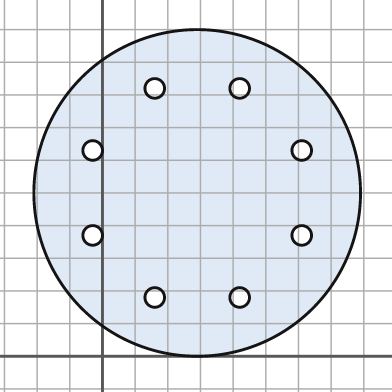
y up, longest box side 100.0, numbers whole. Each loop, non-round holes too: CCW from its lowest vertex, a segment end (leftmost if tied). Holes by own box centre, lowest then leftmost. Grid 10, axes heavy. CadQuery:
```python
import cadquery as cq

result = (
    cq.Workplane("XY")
    .moveTo(29.0, 50.0)
    .circle(50.0)
    .moveTo(16.0, 18.0)
    .circle(3.0)
    .moveTo(42.0, 18.0)
    .circle(3.0)
    .moveTo(-3.0, 37.0)
    .circle(3.0)
    .moveTo(61.0, 37.0)
    .circle(3.0)
    .moveTo(-3.0, 63.0)
    .circle(3.0)
    .moveTo(61.0, 63.0)
    .circle(3.0)
    .moveTo(16.0, 82.0)
    .circle(3.0)
    .moveTo(42.0, 82.0)
    .circle(3.0)
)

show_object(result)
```